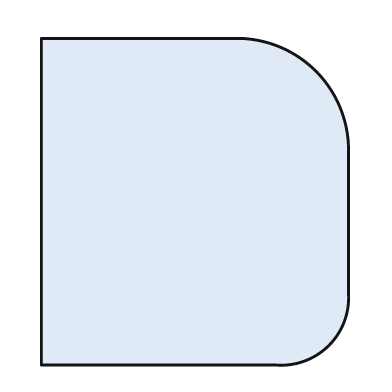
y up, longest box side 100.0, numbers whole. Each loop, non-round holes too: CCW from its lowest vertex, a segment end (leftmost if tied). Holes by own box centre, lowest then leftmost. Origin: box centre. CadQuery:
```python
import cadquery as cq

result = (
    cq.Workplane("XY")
    .moveTo(-47.0, -50.0)
    .lineTo(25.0, -50.0)
    .threePointArc((41.0, -44.0), (47.0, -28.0))
    .lineTo(47.0, 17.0)
    .threePointArc((37.0, 40.0), (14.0, 50.0))
    .lineTo(-47.0, 50.0)
    .close()
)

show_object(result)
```